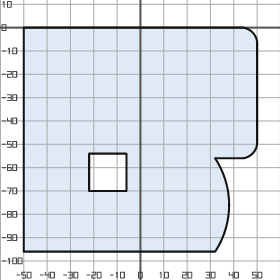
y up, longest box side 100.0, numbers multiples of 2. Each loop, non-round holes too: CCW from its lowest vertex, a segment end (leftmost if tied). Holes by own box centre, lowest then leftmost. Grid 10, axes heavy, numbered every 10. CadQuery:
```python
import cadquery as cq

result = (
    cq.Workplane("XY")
    .moveTo(-50.0, -96.0)
    .lineTo(32.0, -96.0)
    .threePointArc((38.0, -76.0), (32.0, -56.0))
    .lineTo(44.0, -56.0)
    .threePointArc((48.0, -54.0), (50.0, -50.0))
    .lineTo(50.0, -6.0)
    .threePointArc((48.0, -2.0), (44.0, 0.0))
    .lineTo(-50.0, 0.0)
    .close()
    .moveTo(-22.0, -70.0)
    .lineTo(-6.0, -70.0)
    .lineTo(-6.0, -54.0)
    .lineTo(-22.0, -54.0)
    .close()
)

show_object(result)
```